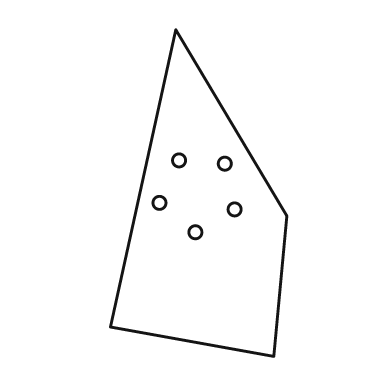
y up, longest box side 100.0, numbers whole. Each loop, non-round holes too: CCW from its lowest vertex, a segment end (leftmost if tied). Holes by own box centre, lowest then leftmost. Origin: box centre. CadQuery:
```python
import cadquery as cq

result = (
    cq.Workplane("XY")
    .moveTo(23.0, -50.0)
    .lineTo(27.0, -7.0)
    .lineTo(-7.0, 50.0)
    .lineTo(-27.0, -41.0)
    .close()
    .moveTo(-1.0, -12.0)
    .circle(2.0)
    .moveTo(11.0, -5.0)
    .circle(2.0)
    .moveTo(-12.0, -3.0)
    .circle(2.0)
    .moveTo(8.0, 9.0)
    .circle(2.0)
    .moveTo(-6.0, 10.0)
    .circle(2.0)
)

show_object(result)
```